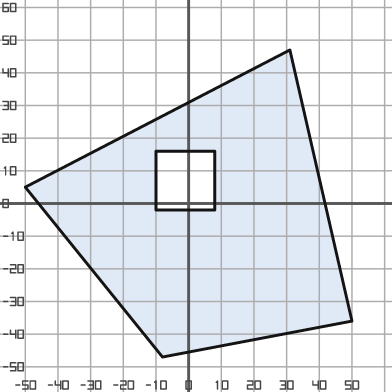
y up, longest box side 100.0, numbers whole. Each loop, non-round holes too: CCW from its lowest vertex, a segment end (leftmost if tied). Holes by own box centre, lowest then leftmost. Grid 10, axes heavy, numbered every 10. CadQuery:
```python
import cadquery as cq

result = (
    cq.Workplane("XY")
    .moveTo(-8.0, -47.0)
    .lineTo(50.0, -36.0)
    .lineTo(31.0, 47.0)
    .lineTo(-50.0, 5.0)
    .close()
    .moveTo(-10.0, -2.0)
    .lineTo(8.0, -2.0)
    .lineTo(8.0, 16.0)
    .lineTo(-10.0, 16.0)
    .close()
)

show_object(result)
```